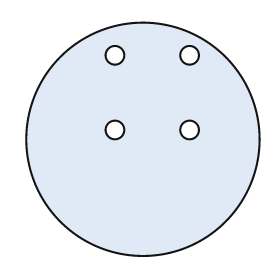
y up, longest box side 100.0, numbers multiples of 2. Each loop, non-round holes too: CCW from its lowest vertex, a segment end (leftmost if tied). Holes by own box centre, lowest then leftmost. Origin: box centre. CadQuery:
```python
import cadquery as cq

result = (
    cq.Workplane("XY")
    .moveTo(0.0, 0.0)
    .circle(50.0)
    .moveTo(-12.0, 4.0)
    .circle(4.0)
    .moveTo(20.0, 4.0)
    .circle(4.0)
    .moveTo(-12.0, 36.0)
    .circle(4.0)
    .moveTo(20.0, 36.0)
    .circle(4.0)
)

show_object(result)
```